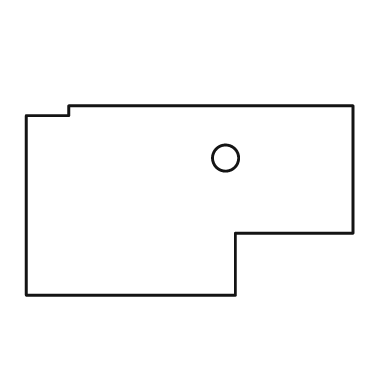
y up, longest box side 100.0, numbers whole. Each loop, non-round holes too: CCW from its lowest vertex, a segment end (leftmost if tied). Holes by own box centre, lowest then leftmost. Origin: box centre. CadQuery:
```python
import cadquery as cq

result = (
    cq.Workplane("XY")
    .moveTo(-50.0, -29.0)
    .lineTo(14.0, -29.0)
    .lineTo(14.0, -10.0)
    .lineTo(50.0, -10.0)
    .lineTo(50.0, 29.0)
    .lineTo(-37.0, 29.0)
    .lineTo(-37.0, 26.0)
    .lineTo(-50.0, 26.0)
    .close()
    .moveTo(11.0, 13.0)
    .circle(4.0)
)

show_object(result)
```